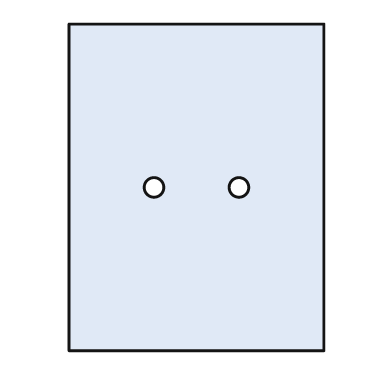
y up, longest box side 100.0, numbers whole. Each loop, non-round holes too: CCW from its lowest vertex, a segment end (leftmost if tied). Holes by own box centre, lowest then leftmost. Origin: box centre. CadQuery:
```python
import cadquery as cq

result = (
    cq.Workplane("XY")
    .moveTo(-39.0, -50.0)
    .lineTo(39.0, -50.0)
    .lineTo(39.0, 50.0)
    .lineTo(-39.0, 50.0)
    .close()
    .moveTo(-13.0, 0.0)
    .circle(3.0)
    .moveTo(13.0, 0.0)
    .circle(3.0)
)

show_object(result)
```